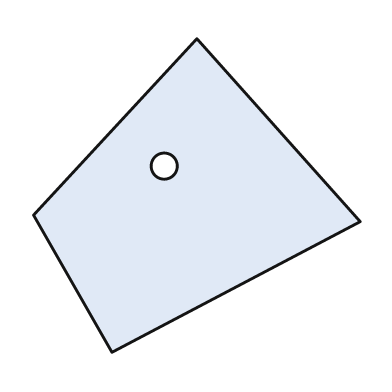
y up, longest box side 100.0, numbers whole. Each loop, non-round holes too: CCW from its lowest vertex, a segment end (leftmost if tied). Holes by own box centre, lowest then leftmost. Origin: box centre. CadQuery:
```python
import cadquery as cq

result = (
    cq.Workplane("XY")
    .moveTo(-26.0, -48.0)
    .lineTo(50.0, -8.0)
    .lineTo(0.0, 48.0)
    .lineTo(-50.0, -6.0)
    .close()
    .moveTo(-10.0, 9.0)
    .circle(4.0)
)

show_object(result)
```